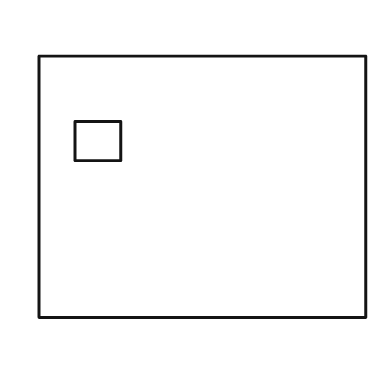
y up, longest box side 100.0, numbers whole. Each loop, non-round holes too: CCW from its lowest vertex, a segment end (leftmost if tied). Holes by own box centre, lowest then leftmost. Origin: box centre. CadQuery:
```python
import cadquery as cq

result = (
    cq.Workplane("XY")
    .moveTo(-50.0, -40.0)
    .lineTo(50.0, -40.0)
    .lineTo(50.0, 40.0)
    .lineTo(-50.0, 40.0)
    .close()
    .moveTo(-39.0, 8.0)
    .lineTo(-25.0, 8.0)
    .lineTo(-25.0, 20.0)
    .lineTo(-39.0, 20.0)
    .close()
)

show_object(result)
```